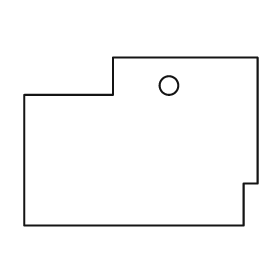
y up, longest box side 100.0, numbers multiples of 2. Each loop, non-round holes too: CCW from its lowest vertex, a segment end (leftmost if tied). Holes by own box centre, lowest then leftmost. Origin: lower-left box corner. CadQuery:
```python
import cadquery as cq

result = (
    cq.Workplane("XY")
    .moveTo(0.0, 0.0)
    .lineTo(94.0, 0.0)
    .lineTo(94.0, 18.0)
    .lineTo(100.0, 18.0)
    .lineTo(100.0, 72.0)
    .lineTo(38.0, 72.0)
    .lineTo(38.0, 56.0)
    .lineTo(0.0, 56.0)
    .close()
    .moveTo(62.0, 60.0)
    .circle(4.0)
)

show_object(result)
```